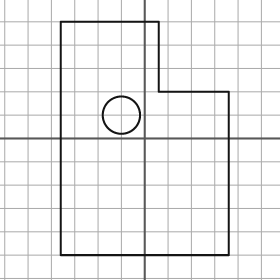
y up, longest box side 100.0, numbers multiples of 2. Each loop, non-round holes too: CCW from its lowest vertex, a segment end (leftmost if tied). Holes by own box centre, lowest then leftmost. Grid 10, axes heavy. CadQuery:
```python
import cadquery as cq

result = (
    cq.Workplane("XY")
    .moveTo(-36.0, -50.0)
    .lineTo(36.0, -50.0)
    .lineTo(36.0, 20.0)
    .lineTo(6.0, 20.0)
    .lineTo(6.0, 50.0)
    .lineTo(-36.0, 50.0)
    .close()
    .moveTo(-10.0, 10.0)
    .circle(8.0)
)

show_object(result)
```